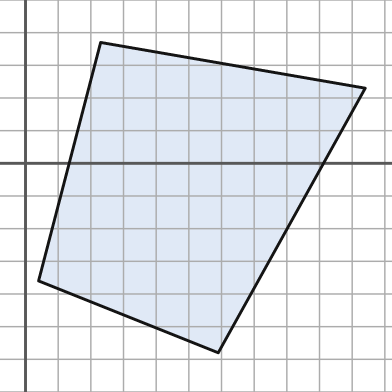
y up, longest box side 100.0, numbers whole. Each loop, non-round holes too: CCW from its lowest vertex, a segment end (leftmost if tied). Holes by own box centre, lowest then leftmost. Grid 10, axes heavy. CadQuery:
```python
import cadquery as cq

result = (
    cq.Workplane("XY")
    .moveTo(59.0, -58.0)
    .lineTo(104.0, 23.0)
    .lineTo(23.0, 37.0)
    .lineTo(4.0, -36.0)
    .close()
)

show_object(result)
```